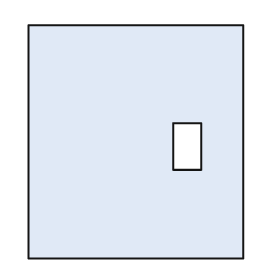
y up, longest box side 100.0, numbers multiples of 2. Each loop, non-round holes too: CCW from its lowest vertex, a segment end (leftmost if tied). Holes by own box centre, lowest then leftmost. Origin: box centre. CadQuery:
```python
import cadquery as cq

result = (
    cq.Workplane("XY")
    .moveTo(-46.0, -50.0)
    .lineTo(46.0, -50.0)
    .lineTo(46.0, 50.0)
    .lineTo(-46.0, 50.0)
    .close()
    .moveTo(16.0, -12.0)
    .lineTo(28.0, -12.0)
    .lineTo(28.0, 8.0)
    .lineTo(16.0, 8.0)
    .close()
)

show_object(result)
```